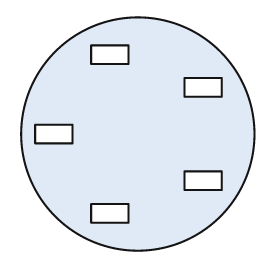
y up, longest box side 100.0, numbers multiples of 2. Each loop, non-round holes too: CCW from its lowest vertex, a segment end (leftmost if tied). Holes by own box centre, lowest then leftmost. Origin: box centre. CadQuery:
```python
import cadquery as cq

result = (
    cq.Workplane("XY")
    .moveTo(0.0, 0.0)
    .circle(50.0)
    .moveTo(-20.0, -38.0)
    .lineTo(-4.0, -38.0)
    .lineTo(-4.0, -30.0)
    .lineTo(-20.0, -30.0)
    .close()
    .moveTo(20.0, -24.0)
    .lineTo(36.0, -24.0)
    .lineTo(36.0, -16.0)
    .lineTo(20.0, -16.0)
    .close()
    .moveTo(-44.0, -4.0)
    .lineTo(-28.0, -4.0)
    .lineTo(-28.0, 4.0)
    .lineTo(-44.0, 4.0)
    .close()
    .moveTo(20.0, 16.0)
    .lineTo(36.0, 16.0)
    .lineTo(36.0, 24.0)
    .lineTo(20.0, 24.0)
    .close()
    .moveTo(-20.0, 30.0)
    .lineTo(-4.0, 30.0)
    .lineTo(-4.0, 38.0)
    .lineTo(-20.0, 38.0)
    .close()
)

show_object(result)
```